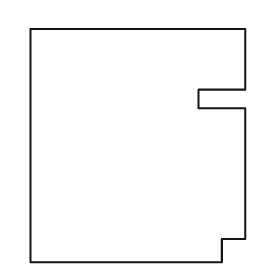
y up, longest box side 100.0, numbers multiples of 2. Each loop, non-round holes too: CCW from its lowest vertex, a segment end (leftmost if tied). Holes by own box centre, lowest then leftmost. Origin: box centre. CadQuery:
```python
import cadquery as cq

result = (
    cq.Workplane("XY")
    .moveTo(-46.0, -50.0)
    .lineTo(36.0, -50.0)
    .lineTo(36.0, -40.0)
    .lineTo(46.0, -40.0)
    .lineTo(46.0, 16.0)
    .lineTo(26.0, 16.0)
    .lineTo(26.0, 24.0)
    .lineTo(46.0, 24.0)
    .lineTo(46.0, 50.0)
    .lineTo(-46.0, 50.0)
    .close()
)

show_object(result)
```